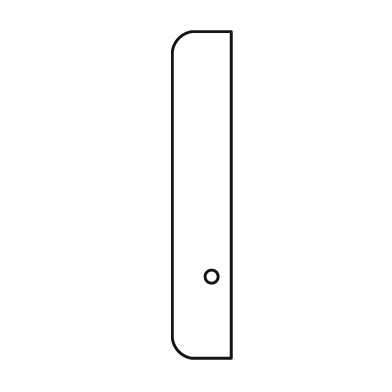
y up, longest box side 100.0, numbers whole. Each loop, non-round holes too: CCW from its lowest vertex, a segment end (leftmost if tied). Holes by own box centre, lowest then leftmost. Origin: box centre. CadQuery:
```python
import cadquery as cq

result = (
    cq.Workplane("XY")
    .moveTo(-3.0, -50.0)
    .lineTo(9.0, -50.0)
    .lineTo(9.0, 50.0)
    .lineTo(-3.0, 50.0)
    .threePointArc((-7.0, 48.0), (-9.0, 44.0))
    .lineTo(-9.0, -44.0)
    .threePointArc((-7.0, -48.0), (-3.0, -50.0))
    .close()
    .moveTo(3.0, -25.0)
    .circle(2.0)
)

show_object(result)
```